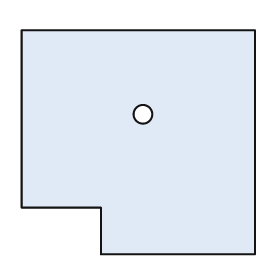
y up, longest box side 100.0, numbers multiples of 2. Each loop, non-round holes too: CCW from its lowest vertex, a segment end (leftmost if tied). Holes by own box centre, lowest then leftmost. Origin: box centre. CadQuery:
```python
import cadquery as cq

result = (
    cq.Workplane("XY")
    .moveTo(-16.0, -48.0)
    .lineTo(50.0, -48.0)
    .lineTo(50.0, 48.0)
    .lineTo(-50.0, 48.0)
    .lineTo(-50.0, -28.0)
    .lineTo(-16.0, -28.0)
    .close()
    .moveTo(2.0, 12.0)
    .circle(4.0)
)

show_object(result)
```